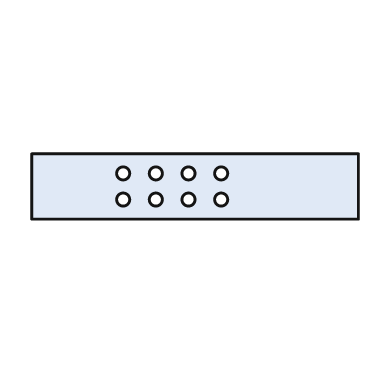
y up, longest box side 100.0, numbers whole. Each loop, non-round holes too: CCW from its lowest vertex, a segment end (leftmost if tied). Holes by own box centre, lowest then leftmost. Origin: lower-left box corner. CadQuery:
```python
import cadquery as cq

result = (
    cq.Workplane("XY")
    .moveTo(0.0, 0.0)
    .lineTo(100.0, 0.0)
    .lineTo(100.0, 20.0)
    .lineTo(0.0, 20.0)
    .close()
    .moveTo(28.0, 6.0)
    .circle(2.0)
    .moveTo(38.0, 6.0)
    .circle(2.0)
    .moveTo(48.0, 6.0)
    .circle(2.0)
    .moveTo(58.0, 6.0)
    .circle(2.0)
    .moveTo(28.0, 14.0)
    .circle(2.0)
    .moveTo(38.0, 14.0)
    .circle(2.0)
    .moveTo(48.0, 14.0)
    .circle(2.0)
    .moveTo(58.0, 14.0)
    .circle(2.0)
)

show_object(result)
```